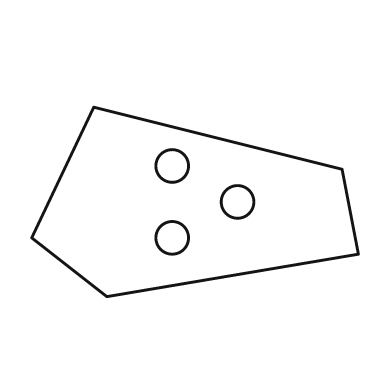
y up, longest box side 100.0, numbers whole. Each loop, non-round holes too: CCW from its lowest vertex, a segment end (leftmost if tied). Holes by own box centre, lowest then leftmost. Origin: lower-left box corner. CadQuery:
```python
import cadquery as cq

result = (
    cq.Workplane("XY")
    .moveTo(23.0, 0.0)
    .lineTo(100.0, 13.0)
    .lineTo(95.0, 39.0)
    .lineTo(19.0, 58.0)
    .lineTo(0.0, 18.0)
    .close()
    .moveTo(43.0, 18.0)
    .circle(5.0)
    .moveTo(63.0, 29.0)
    .circle(5.0)
    .moveTo(43.0, 40.0)
    .circle(5.0)
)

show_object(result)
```